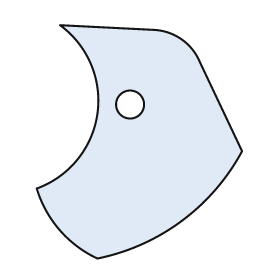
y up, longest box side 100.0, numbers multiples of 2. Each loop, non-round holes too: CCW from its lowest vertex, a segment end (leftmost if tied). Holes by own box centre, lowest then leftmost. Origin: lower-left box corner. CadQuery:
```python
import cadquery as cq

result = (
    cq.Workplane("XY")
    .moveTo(26.0, 0.0)
    .threePointArc((62.0, 16.0), (88.0, 46.0))
    .lineTo(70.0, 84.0)
    .threePointArc((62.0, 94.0), (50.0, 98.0))
    .lineTo(10.0, 100.0)
    .threePointArc((26.0, 62.0), (0.0, 30.0))
    .threePointArc((10.0, 12.0), (26.0, 0.0))
    .close()
    .moveTo(40.0, 66.0)
    .circle(6.0)
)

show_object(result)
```